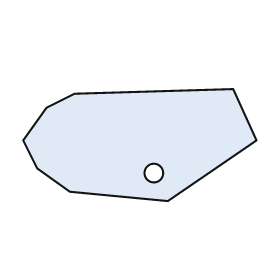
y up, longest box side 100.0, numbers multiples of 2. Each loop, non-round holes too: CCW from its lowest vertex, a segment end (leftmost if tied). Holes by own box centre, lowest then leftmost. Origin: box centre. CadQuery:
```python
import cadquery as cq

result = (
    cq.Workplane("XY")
    .moveTo(12.0, -24.0)
    .lineTo(50.0, 2.0)
    .lineTo(40.0, 24.0)
    .lineTo(-28.0, 22.0)
    .lineTo(-40.0, 16.0)
    .lineTo(-50.0, 2.0)
    .lineTo(-44.0, -10.0)
    .lineTo(-30.0, -20.0)
    .close()
    .moveTo(6.0, -12.0)
    .circle(4.0)
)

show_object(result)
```